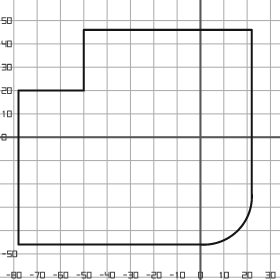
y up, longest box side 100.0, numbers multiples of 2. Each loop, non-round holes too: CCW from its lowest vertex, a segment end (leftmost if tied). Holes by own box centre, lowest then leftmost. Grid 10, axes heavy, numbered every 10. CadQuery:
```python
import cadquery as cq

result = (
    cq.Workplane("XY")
    .moveTo(-78.0, -46.0)
    .lineTo(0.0, -46.0)
    .threePointArc((16.0, -40.0), (22.0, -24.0))
    .lineTo(22.0, 46.0)
    .lineTo(-50.0, 46.0)
    .lineTo(-50.0, 20.0)
    .lineTo(-78.0, 20.0)
    .close()
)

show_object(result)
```